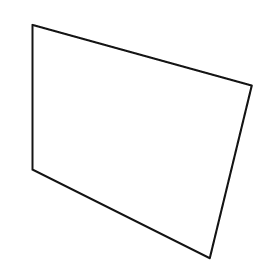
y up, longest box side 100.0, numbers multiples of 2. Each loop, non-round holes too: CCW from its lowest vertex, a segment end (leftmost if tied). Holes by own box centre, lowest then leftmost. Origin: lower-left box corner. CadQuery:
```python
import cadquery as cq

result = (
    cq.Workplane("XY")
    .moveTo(76.0, 0.0)
    .lineTo(94.0, 74.0)
    .lineTo(0.0, 100.0)
    .lineTo(0.0, 38.0)
    .close()
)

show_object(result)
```